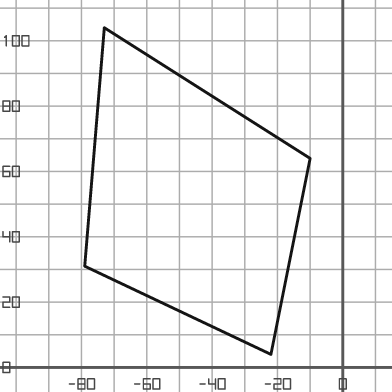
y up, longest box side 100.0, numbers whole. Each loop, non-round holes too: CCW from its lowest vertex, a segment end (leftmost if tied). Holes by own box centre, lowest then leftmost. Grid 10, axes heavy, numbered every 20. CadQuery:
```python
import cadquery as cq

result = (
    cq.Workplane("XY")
    .moveTo(-22.0, 4.0)
    .lineTo(-10.0, 64.0)
    .lineTo(-73.0, 104.0)
    .lineTo(-79.0, 31.0)
    .close()
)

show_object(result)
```